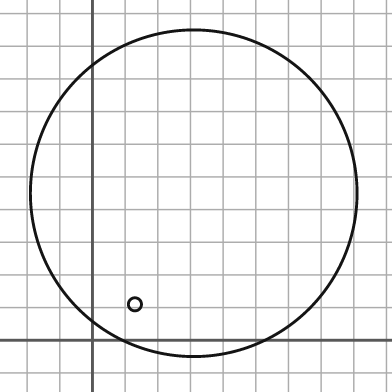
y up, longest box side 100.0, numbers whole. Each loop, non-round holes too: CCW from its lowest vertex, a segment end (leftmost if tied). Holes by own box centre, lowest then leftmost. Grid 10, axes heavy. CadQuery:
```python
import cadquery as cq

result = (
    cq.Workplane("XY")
    .moveTo(31.0, 45.0)
    .circle(50.0)
    .moveTo(13.0, 11.0)
    .circle(2.0)
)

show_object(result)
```